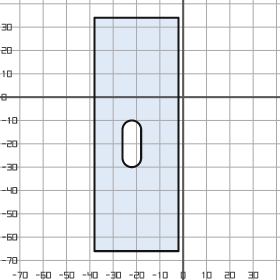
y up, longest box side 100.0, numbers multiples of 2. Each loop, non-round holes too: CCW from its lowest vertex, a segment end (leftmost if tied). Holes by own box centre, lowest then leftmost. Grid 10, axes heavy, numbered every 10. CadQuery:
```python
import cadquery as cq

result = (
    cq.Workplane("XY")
    .moveTo(-38.0, -66.0)
    .lineTo(-2.0, -66.0)
    .lineTo(-2.0, 34.0)
    .lineTo(-38.0, 34.0)
    .close()
    .moveTo(-26.0, -26.0)
    .threePointArc((-22.0, -30.0), (-18.0, -26.0))
    .lineTo(-18.0, -14.0)
    .threePointArc((-22.0, -10.0), (-26.0, -14.0))
    .close()
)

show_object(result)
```